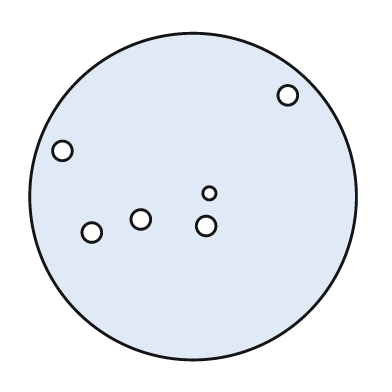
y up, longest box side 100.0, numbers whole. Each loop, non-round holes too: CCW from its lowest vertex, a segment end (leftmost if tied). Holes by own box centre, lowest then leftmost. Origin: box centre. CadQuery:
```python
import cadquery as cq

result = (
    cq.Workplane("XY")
    .moveTo(0.0, 0.0)
    .circle(50.0)
    .moveTo(-31.0, -11.0)
    .circle(3.0)
    .moveTo(4.0, -9.0)
    .circle(3.0)
    .moveTo(-16.0, -7.0)
    .circle(3.0)
    .moveTo(5.0, 1.0)
    .circle(2.0)
    .moveTo(-40.0, 14.0)
    .circle(3.0)
    .moveTo(29.0, 31.0)
    .circle(3.0)
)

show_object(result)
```